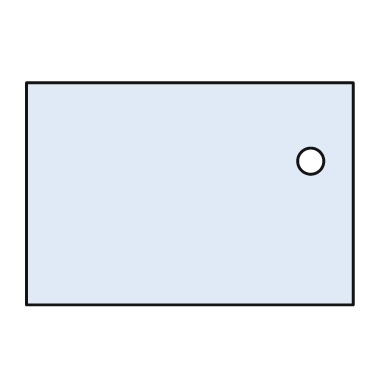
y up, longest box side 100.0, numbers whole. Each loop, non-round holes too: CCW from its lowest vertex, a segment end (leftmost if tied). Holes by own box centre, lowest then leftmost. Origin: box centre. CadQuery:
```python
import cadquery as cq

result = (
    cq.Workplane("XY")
    .moveTo(-50.0, -34.0)
    .lineTo(50.0, -34.0)
    .lineTo(50.0, 34.0)
    .lineTo(-50.0, 34.0)
    .close()
    .moveTo(37.0, 10.0)
    .circle(4.0)
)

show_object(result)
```